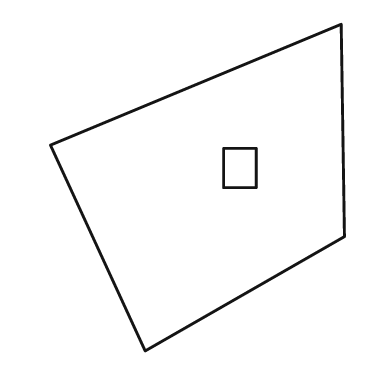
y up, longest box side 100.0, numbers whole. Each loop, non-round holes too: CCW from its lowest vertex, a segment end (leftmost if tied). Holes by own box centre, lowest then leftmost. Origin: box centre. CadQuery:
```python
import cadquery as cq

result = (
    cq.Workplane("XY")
    .moveTo(-16.0, -50.0)
    .lineTo(45.0, -15.0)
    .lineTo(44.0, 50.0)
    .lineTo(-45.0, 13.0)
    .close()
    .moveTo(8.0, 0.0)
    .lineTo(18.0, 0.0)
    .lineTo(18.0, 12.0)
    .lineTo(8.0, 12.0)
    .close()
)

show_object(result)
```